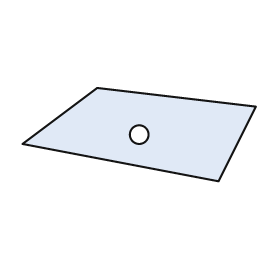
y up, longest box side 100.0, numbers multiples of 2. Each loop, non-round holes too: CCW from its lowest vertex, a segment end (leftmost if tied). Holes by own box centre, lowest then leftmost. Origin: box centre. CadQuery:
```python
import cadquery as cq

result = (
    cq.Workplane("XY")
    .moveTo(34.0, -20.0)
    .lineTo(50.0, 12.0)
    .lineTo(-18.0, 20.0)
    .lineTo(-50.0, -4.0)
    .close()
    .moveTo(0.0, 0.0)
    .circle(4.0)
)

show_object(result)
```